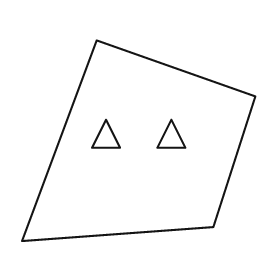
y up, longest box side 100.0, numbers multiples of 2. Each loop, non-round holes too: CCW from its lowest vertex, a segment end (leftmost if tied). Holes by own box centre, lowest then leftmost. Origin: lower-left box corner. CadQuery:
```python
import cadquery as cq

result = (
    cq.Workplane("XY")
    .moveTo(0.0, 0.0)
    .lineTo(82.0, 6.0)
    .lineTo(100.0, 62.0)
    .lineTo(32.0, 86.0)
    .close()
    .moveTo(30.0, 40.0)
    .lineTo(42.0, 40.0)
    .lineTo(36.0, 52.0)
    .close()
    .moveTo(58.0, 40.0)
    .lineTo(70.0, 40.0)
    .lineTo(64.0, 52.0)
    .close()
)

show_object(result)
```